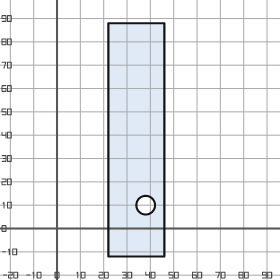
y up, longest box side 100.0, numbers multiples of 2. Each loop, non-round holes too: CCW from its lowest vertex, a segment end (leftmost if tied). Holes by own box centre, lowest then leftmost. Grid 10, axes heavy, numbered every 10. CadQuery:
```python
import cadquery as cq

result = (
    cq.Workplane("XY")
    .moveTo(22.0, -12.0)
    .lineTo(46.0, -12.0)
    .lineTo(46.0, 88.0)
    .lineTo(22.0, 88.0)
    .close()
    .moveTo(38.0, 10.0)
    .circle(4.0)
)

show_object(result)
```